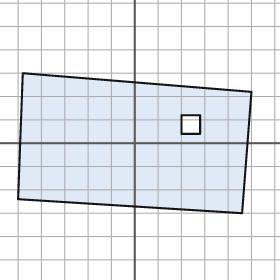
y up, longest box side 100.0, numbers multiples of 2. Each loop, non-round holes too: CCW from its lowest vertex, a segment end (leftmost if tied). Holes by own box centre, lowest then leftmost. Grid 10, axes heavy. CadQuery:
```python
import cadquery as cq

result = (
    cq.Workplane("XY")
    .moveTo(46.0, -30.0)
    .lineTo(50.0, 22.0)
    .lineTo(-48.0, 30.0)
    .lineTo(-50.0, -24.0)
    .close()
    .moveTo(20.0, 4.0)
    .lineTo(28.0, 4.0)
    .lineTo(28.0, 12.0)
    .lineTo(20.0, 12.0)
    .close()
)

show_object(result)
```